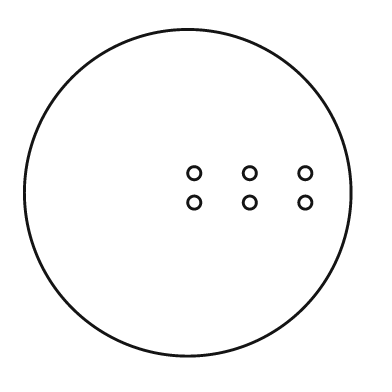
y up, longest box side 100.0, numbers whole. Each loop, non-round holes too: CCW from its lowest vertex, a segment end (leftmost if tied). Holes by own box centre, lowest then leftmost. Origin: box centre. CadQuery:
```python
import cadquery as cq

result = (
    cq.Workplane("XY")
    .moveTo(0.0, 0.0)
    .circle(50.0)
    .moveTo(2.0, -3.0)
    .circle(2.0)
    .moveTo(19.0, -3.0)
    .circle(2.0)
    .moveTo(36.0, -3.0)
    .circle(2.0)
    .moveTo(2.0, 6.0)
    .circle(2.0)
    .moveTo(19.0, 6.0)
    .circle(2.0)
    .moveTo(36.0, 6.0)
    .circle(2.0)
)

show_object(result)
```